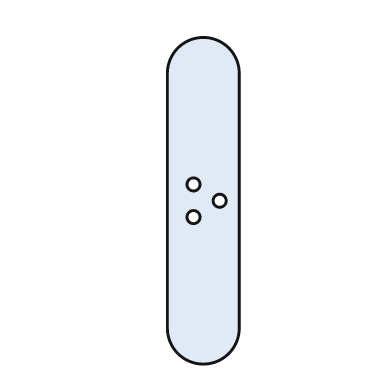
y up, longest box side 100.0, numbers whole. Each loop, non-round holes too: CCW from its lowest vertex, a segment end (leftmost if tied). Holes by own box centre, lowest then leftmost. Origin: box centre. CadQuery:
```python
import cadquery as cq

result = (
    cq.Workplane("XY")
    .moveTo(-11.0, -39.0)
    .threePointArc((0.0, -50.0), (11.0, -39.0))
    .lineTo(11.0, 39.0)
    .threePointArc((0.0, 50.0), (-11.0, 39.0))
    .close()
    .moveTo(-3.0, -5.0)
    .circle(2.0)
    .moveTo(5.0, 0.0)
    .circle(2.0)
    .moveTo(-3.0, 5.0)
    .circle(2.0)
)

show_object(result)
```